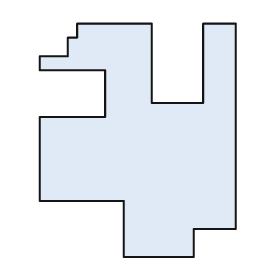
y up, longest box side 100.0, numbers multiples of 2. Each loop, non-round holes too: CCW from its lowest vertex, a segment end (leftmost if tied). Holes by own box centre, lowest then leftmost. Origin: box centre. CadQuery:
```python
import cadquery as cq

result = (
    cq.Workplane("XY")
    .moveTo(-6.0, -50.0)
    .lineTo(24.0, -50.0)
    .lineTo(24.0, -38.0)
    .lineTo(42.0, -38.0)
    .lineTo(42.0, 50.0)
    .lineTo(28.0, 50.0)
    .lineTo(28.0, 16.0)
    .lineTo(6.0, 16.0)
    .lineTo(6.0, 50.0)
    .lineTo(-26.0, 50.0)
    .lineTo(-26.0, 44.0)
    .lineTo(-30.0, 44.0)
    .lineTo(-30.0, 36.0)
    .lineTo(-42.0, 36.0)
    .lineTo(-42.0, 30.0)
    .lineTo(-14.0, 30.0)
    .lineTo(-14.0, 10.0)
    .lineTo(-42.0, 10.0)
    .lineTo(-42.0, -26.0)
    .lineTo(-6.0, -26.0)
    .close()
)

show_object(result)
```